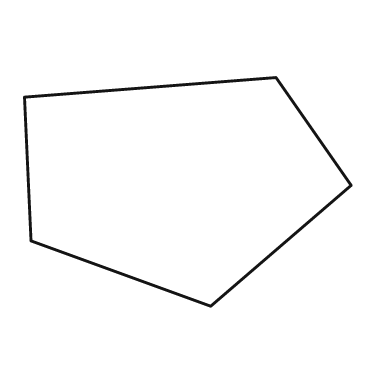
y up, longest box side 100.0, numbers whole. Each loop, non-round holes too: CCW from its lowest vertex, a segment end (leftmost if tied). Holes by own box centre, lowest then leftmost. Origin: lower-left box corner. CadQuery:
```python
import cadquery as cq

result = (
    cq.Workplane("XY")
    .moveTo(57.0, 0.0)
    .lineTo(100.0, 37.0)
    .lineTo(77.0, 70.0)
    .lineTo(0.0, 64.0)
    .lineTo(2.0, 20.0)
    .close()
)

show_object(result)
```